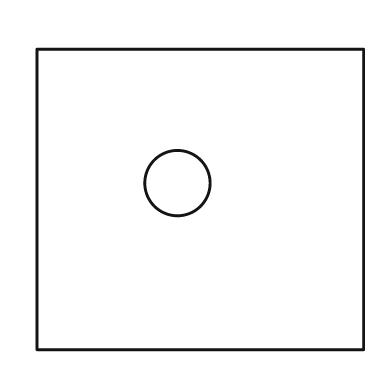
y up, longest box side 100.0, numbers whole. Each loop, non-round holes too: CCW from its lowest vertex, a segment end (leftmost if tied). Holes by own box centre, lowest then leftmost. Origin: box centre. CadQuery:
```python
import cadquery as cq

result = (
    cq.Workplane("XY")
    .moveTo(-50.0, -46.0)
    .lineTo(50.0, -46.0)
    .lineTo(50.0, 46.0)
    .lineTo(-50.0, 46.0)
    .close()
    .moveTo(-7.0, 5.0)
    .circle(10.0)
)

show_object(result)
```